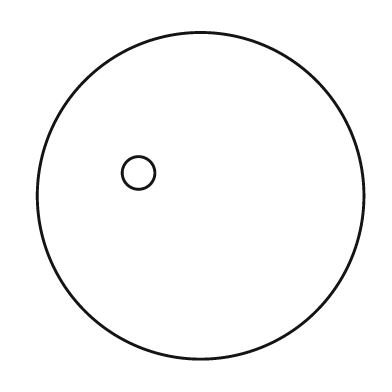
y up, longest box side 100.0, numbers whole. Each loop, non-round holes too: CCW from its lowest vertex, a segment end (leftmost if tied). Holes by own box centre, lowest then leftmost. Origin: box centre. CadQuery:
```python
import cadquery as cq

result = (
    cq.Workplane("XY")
    .moveTo(0.0, 0.0)
    .circle(50.0)
    .moveTo(-19.0, 7.0)
    .circle(5.0)
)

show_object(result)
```